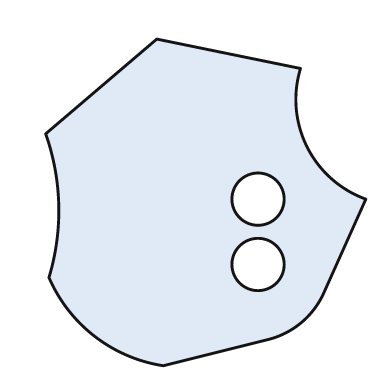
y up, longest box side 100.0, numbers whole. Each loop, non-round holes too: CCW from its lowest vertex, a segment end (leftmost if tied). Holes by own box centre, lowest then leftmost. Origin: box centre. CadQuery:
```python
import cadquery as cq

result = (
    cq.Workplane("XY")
    .moveTo(-13.0, -50.0)
    .lineTo(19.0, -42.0)
    .threePointArc((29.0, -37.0), (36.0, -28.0))
    .lineTo(49.0, 1.0)
    .threePointArc((31.0, 17.0), (29.0, 41.0))
    .lineTo(-15.0, 50.0)
    .lineTo(-49.0, 21.0)
    .threePointArc((-45.0, -1.0), (-48.0, -23.0))
    .threePointArc((-34.0, -41.0), (-13.0, -50.0))
    .close()
    .moveTo(16.0, -19.0)
    .circle(8.0)
    .moveTo(16.0, 1.0)
    .circle(8.0)
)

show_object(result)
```